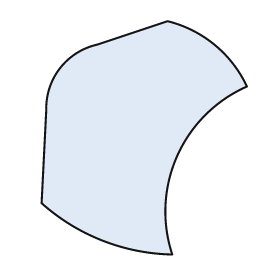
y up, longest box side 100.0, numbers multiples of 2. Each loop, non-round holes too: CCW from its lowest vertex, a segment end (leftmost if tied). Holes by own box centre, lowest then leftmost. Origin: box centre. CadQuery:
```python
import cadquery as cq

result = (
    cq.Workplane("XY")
    .moveTo(12.0, -50.0)
    .threePointArc((14.0, -8.0), (44.0, 22.0))
    .threePointArc((30.0, 40.0), (10.0, 50.0))
    .lineTo(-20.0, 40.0)
    .threePointArc((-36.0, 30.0), (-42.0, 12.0))
    .lineTo(-44.0, -28.0)
    .threePointArc((-18.0, -44.0), (12.0, -50.0))
    .close()
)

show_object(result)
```